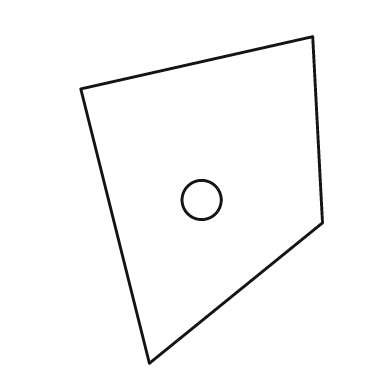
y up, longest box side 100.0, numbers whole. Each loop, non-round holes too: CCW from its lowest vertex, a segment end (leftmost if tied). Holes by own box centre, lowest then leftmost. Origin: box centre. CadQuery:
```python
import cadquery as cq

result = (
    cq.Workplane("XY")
    .moveTo(-16.0, -50.0)
    .lineTo(37.0, -7.0)
    .lineTo(34.0, 50.0)
    .lineTo(-37.0, 34.0)
    .close()
    .moveTo(0.0, 0.0)
    .circle(6.0)
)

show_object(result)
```